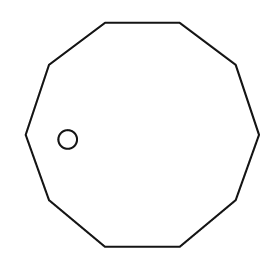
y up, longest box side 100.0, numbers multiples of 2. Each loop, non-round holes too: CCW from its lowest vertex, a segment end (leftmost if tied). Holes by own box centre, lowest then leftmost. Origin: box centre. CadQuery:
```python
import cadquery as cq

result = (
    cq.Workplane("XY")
    .moveTo(-16.0, -48.0)
    .lineTo(16.0, -48.0)
    .lineTo(40.0, -28.0)
    .lineTo(50.0, 0.0)
    .lineTo(40.0, 30.0)
    .lineTo(16.0, 48.0)
    .lineTo(-16.0, 48.0)
    .lineTo(-40.0, 30.0)
    .lineTo(-50.0, 0.0)
    .lineTo(-40.0, -28.0)
    .close()
    .moveTo(-32.0, -2.0)
    .circle(4.0)
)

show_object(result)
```